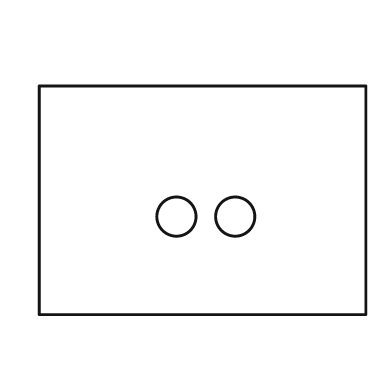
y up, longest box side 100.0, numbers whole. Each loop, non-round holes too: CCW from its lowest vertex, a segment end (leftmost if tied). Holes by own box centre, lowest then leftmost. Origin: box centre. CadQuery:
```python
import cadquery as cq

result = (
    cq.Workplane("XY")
    .moveTo(-50.0, -35.0)
    .lineTo(50.0, -35.0)
    .lineTo(50.0, 35.0)
    .lineTo(-50.0, 35.0)
    .close()
    .moveTo(-8.0, -5.0)
    .circle(6.0)
    .moveTo(10.0, -5.0)
    .circle(6.0)
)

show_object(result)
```